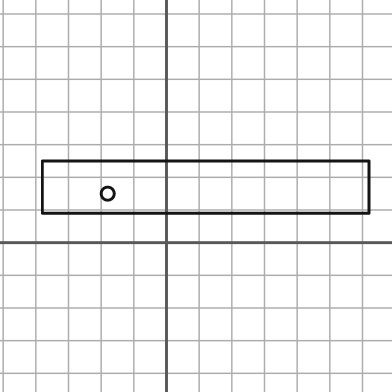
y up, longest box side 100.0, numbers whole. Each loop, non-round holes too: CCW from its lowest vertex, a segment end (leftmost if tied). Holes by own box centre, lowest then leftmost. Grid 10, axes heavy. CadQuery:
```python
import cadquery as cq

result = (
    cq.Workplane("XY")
    .moveTo(-38.0, 9.0)
    .lineTo(62.0, 9.0)
    .lineTo(62.0, 25.0)
    .lineTo(-38.0, 25.0)
    .close()
    .moveTo(-18.0, 15.0)
    .circle(2.0)
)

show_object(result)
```